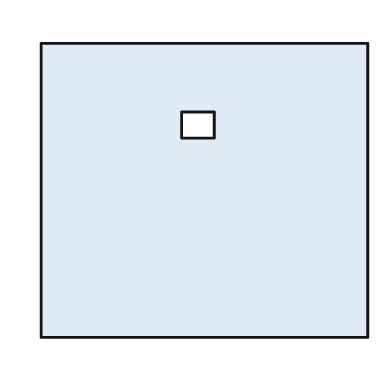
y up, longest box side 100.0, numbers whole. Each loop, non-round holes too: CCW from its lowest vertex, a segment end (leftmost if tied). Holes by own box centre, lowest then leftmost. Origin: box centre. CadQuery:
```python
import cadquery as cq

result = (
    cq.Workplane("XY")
    .moveTo(-50.0, -45.0)
    .lineTo(50.0, -45.0)
    .lineTo(50.0, 45.0)
    .lineTo(-50.0, 45.0)
    .close()
    .moveTo(-7.0, 16.0)
    .lineTo(3.0, 16.0)
    .lineTo(3.0, 24.0)
    .lineTo(-7.0, 24.0)
    .close()
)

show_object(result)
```